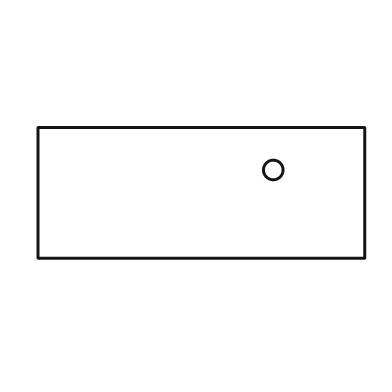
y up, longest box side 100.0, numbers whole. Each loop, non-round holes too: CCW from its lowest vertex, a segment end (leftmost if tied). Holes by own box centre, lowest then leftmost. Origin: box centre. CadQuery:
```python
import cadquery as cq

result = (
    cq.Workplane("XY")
    .moveTo(-50.0, -20.0)
    .lineTo(50.0, -20.0)
    .lineTo(50.0, 20.0)
    .lineTo(-50.0, 20.0)
    .close()
    .moveTo(22.0, 7.0)
    .circle(3.0)
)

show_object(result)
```